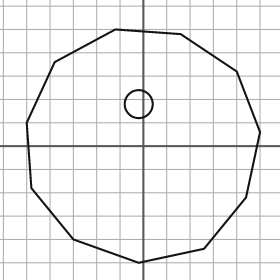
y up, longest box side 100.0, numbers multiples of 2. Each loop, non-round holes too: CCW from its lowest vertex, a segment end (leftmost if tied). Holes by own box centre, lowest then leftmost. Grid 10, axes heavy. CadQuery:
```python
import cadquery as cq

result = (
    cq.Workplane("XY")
    .moveTo(-2.0, -50.0)
    .lineTo(26.0, -44.0)
    .lineTo(44.0, -22.0)
    .lineTo(50.0, 6.0)
    .lineTo(40.0, 32.0)
    .lineTo(16.0, 48.0)
    .lineTo(-12.0, 50.0)
    .lineTo(-38.0, 36.0)
    .lineTo(-50.0, 10.0)
    .lineTo(-48.0, -18.0)
    .lineTo(-30.0, -40.0)
    .close()
    .moveTo(-2.0, 18.0)
    .circle(6.0)
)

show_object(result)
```